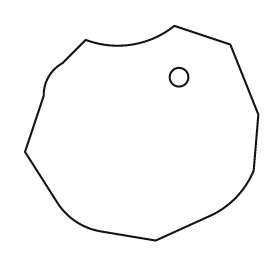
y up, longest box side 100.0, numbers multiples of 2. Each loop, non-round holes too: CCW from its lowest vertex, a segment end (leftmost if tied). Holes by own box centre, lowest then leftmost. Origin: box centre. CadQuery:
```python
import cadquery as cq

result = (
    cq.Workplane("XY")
    .moveTo(6.0, -46.0)
    .lineTo(28.0, -36.0)
    .threePointArc((40.0, -28.0), (48.0, -16.0))
    .lineTo(50.0, 8.0)
    .lineTo(38.0, 38.0)
    .lineTo(14.0, 46.0)
    .threePointArc((-4.0, 38.0), (-24.0, 40.0))
    .lineTo(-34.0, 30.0)
    .threePointArc((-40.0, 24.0), (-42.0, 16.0))
    .lineTo(-50.0, -8.0)
    .lineTo(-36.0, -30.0)
    .threePointArc((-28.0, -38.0), (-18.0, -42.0))
    .close()
    .moveTo(16.0, 24.0)
    .circle(4.0)
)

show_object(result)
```